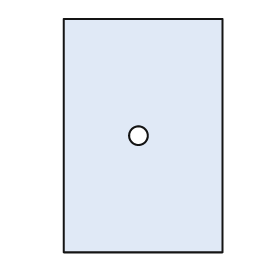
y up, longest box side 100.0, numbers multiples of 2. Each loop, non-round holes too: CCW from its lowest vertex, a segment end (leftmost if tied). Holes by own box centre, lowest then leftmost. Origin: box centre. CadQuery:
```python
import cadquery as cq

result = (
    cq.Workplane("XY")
    .moveTo(-34.0, -50.0)
    .lineTo(34.0, -50.0)
    .lineTo(34.0, 50.0)
    .lineTo(-34.0, 50.0)
    .close()
    .moveTo(-2.0, 0.0)
    .circle(4.0)
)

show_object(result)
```